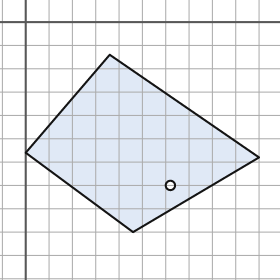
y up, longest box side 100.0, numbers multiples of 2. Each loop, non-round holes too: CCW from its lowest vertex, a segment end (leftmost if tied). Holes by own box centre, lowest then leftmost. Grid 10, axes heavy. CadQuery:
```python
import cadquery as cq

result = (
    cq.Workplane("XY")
    .moveTo(46.0, -90.0)
    .lineTo(100.0, -58.0)
    .lineTo(36.0, -14.0)
    .lineTo(0.0, -56.0)
    .close()
    .moveTo(62.0, -70.0)
    .circle(2.0)
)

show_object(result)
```